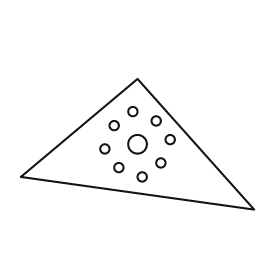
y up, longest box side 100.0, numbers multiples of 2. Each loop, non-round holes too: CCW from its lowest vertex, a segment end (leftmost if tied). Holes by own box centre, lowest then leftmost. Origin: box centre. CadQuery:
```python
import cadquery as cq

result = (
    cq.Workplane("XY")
    .moveTo(50.0, -28.0)
    .lineTo(0.0, 28.0)
    .lineTo(-50.0, -14.0)
    .close()
    .moveTo(2.0, -14.0)
    .circle(2.0)
    .moveTo(-8.0, -10.0)
    .circle(2.0)
    .moveTo(10.0, -8.0)
    .circle(2.0)
    .moveTo(-14.0, -2.0)
    .circle(2.0)
    .moveTo(0.0, 0.0)
    .circle(4.0)
    .moveTo(14.0, 2.0)
    .circle(2.0)
    .moveTo(-10.0, 8.0)
    .circle(2.0)
    .moveTo(8.0, 10.0)
    .circle(2.0)
    .moveTo(-2.0, 14.0)
    .circle(2.0)
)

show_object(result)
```